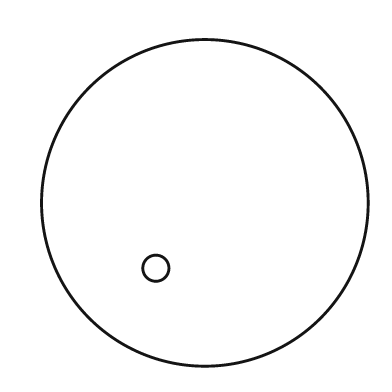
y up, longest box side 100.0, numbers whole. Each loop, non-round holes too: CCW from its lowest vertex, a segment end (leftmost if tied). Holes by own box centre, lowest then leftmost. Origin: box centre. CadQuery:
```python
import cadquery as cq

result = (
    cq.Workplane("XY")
    .moveTo(0.0, 0.0)
    .circle(50.0)
    .moveTo(-15.0, -20.0)
    .circle(4.0)
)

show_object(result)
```